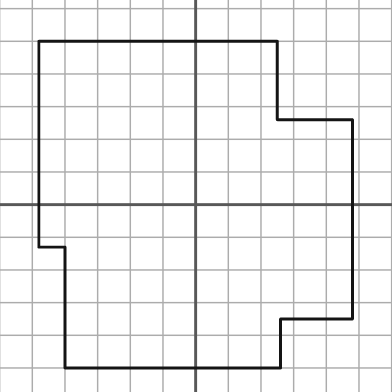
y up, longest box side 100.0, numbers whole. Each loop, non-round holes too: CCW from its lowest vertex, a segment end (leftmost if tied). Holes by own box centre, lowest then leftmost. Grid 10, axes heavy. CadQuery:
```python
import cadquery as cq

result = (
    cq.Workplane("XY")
    .moveTo(-40.0, -50.0)
    .lineTo(26.0, -50.0)
    .lineTo(26.0, -35.0)
    .lineTo(48.0, -35.0)
    .lineTo(48.0, 26.0)
    .lineTo(25.0, 26.0)
    .lineTo(25.0, 50.0)
    .lineTo(-48.0, 50.0)
    .lineTo(-48.0, -13.0)
    .lineTo(-40.0, -13.0)
    .close()
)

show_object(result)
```